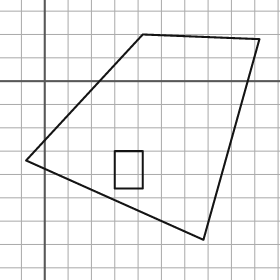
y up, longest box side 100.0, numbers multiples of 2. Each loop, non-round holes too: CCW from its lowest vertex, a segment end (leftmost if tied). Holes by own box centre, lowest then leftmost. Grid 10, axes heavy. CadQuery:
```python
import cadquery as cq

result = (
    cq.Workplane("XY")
    .moveTo(68.0, -68.0)
    .lineTo(92.0, 18.0)
    .lineTo(42.0, 20.0)
    .lineTo(-8.0, -34.0)
    .close()
    .moveTo(30.0, -46.0)
    .lineTo(42.0, -46.0)
    .lineTo(42.0, -30.0)
    .lineTo(30.0, -30.0)
    .close()
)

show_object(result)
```